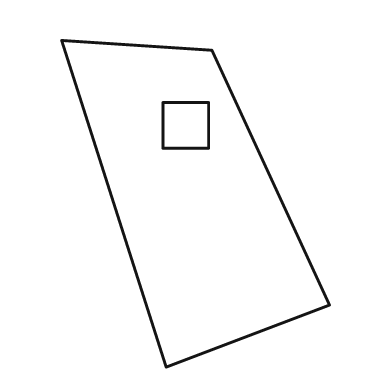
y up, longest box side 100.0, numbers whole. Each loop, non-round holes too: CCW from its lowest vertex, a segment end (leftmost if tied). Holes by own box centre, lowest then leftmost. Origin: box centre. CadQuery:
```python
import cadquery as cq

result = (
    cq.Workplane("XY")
    .moveTo(-9.0, -50.0)
    .lineTo(41.0, -31.0)
    .lineTo(5.0, 47.0)
    .lineTo(-41.0, 50.0)
    .close()
    .moveTo(-10.0, 17.0)
    .lineTo(4.0, 17.0)
    .lineTo(4.0, 31.0)
    .lineTo(-10.0, 31.0)
    .close()
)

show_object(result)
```